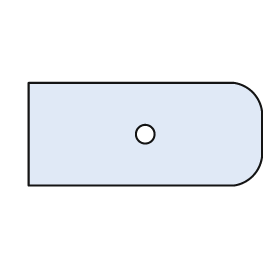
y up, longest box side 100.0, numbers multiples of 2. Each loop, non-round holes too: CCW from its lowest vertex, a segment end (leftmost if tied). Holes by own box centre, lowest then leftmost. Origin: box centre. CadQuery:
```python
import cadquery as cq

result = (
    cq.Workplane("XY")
    .moveTo(-50.0, -22.0)
    .lineTo(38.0, -22.0)
    .threePointArc((46.0, -18.0), (50.0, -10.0))
    .lineTo(50.0, 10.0)
    .threePointArc((46.0, 18.0), (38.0, 22.0))
    .lineTo(-50.0, 22.0)
    .close()
    .moveTo(0.0, 0.0)
    .circle(4.0)
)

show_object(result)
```